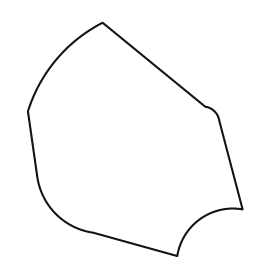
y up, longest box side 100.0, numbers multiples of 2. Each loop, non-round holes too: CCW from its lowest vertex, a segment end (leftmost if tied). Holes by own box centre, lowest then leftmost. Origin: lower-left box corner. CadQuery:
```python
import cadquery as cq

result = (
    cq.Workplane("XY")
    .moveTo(64.0, 0.0)
    .threePointArc((74.0, 16.0), (92.0, 20.0))
    .lineTo(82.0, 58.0)
    .threePointArc((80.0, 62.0), (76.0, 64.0))
    .lineTo(32.0, 100.0)
    .threePointArc((12.0, 84.0), (0.0, 62.0))
    .lineTo(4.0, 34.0)
    .threePointArc((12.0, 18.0), (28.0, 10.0))
    .close()
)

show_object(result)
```